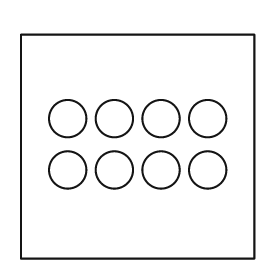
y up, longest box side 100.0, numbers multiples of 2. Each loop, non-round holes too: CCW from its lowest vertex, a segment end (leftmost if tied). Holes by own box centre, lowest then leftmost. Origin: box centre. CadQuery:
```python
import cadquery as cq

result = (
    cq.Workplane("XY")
    .moveTo(-50.0, -48.0)
    .lineTo(50.0, -48.0)
    .lineTo(50.0, 48.0)
    .lineTo(-50.0, 48.0)
    .close()
    .moveTo(-30.0, -10.0)
    .circle(8.0)
    .moveTo(-10.0, -10.0)
    .circle(8.0)
    .moveTo(10.0, -10.0)
    .circle(8.0)
    .moveTo(30.0, -10.0)
    .circle(8.0)
    .moveTo(-30.0, 12.0)
    .circle(8.0)
    .moveTo(-10.0, 12.0)
    .circle(8.0)
    .moveTo(10.0, 12.0)
    .circle(8.0)
    .moveTo(30.0, 12.0)
    .circle(8.0)
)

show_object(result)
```